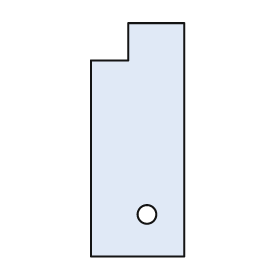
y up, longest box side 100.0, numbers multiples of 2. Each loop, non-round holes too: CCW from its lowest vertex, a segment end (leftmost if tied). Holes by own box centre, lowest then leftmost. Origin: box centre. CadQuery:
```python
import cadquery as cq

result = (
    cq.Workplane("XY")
    .moveTo(-20.0, -50.0)
    .lineTo(20.0, -50.0)
    .lineTo(20.0, 50.0)
    .lineTo(-4.0, 50.0)
    .lineTo(-4.0, 34.0)
    .lineTo(-20.0, 34.0)
    .close()
    .moveTo(4.0, -32.0)
    .circle(4.0)
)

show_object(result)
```